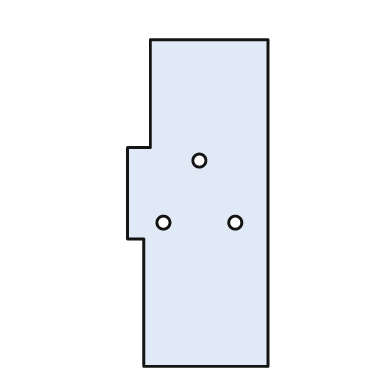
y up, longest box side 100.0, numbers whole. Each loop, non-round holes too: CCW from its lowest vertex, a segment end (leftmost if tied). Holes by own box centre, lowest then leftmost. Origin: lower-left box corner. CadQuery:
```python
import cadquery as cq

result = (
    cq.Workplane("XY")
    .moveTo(5.0, 0.0)
    .lineTo(43.0, 0.0)
    .lineTo(43.0, 100.0)
    .lineTo(7.0, 100.0)
    .lineTo(7.0, 67.0)
    .lineTo(0.0, 67.0)
    .lineTo(0.0, 39.0)
    .lineTo(5.0, 39.0)
    .close()
    .moveTo(11.0, 44.0)
    .circle(2.0)
    .moveTo(33.0, 44.0)
    .circle(2.0)
    .moveTo(22.0, 63.0)
    .circle(2.0)
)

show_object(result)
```